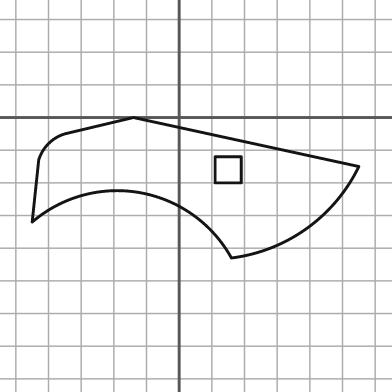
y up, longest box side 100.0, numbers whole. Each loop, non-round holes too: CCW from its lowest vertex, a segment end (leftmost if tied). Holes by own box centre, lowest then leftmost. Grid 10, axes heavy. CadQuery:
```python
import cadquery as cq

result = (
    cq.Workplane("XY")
    .moveTo(16.0, -43.0)
    .threePointArc((39.0, -34.0), (55.0, -15.0))
    .lineTo(-14.0, 0.0)
    .lineTo(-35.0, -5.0)
    .threePointArc((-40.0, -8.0), (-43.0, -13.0))
    .lineTo(-45.0, -32.0)
    .threePointArc((-12.0, -23.0), (16.0, -43.0))
    .close()
    .moveTo(11.0, -20.0)
    .lineTo(19.0, -20.0)
    .lineTo(19.0, -12.0)
    .lineTo(11.0, -12.0)
    .close()
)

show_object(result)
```